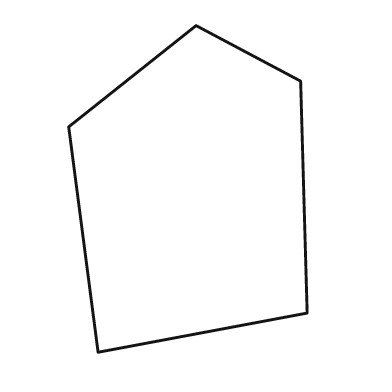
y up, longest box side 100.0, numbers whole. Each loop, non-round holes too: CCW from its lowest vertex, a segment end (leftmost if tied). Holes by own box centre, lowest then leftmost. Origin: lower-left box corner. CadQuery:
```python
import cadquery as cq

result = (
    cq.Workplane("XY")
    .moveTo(9.0, 0.0)
    .lineTo(73.0, 12.0)
    .lineTo(71.0, 83.0)
    .lineTo(39.0, 100.0)
    .lineTo(0.0, 69.0)
    .close()
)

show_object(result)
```